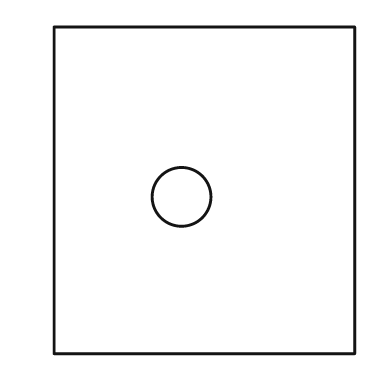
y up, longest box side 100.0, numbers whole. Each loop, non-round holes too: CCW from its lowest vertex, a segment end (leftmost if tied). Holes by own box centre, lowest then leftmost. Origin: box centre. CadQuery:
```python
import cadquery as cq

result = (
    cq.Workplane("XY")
    .moveTo(-46.0, -50.0)
    .lineTo(46.0, -50.0)
    .lineTo(46.0, 50.0)
    .lineTo(-46.0, 50.0)
    .close()
    .moveTo(-7.0, -2.0)
    .circle(9.0)
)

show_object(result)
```